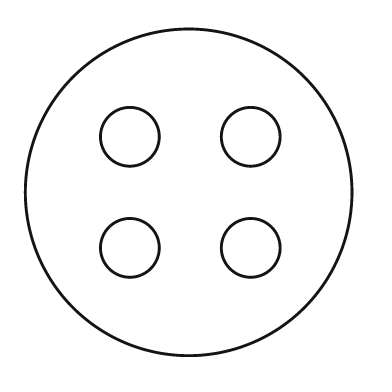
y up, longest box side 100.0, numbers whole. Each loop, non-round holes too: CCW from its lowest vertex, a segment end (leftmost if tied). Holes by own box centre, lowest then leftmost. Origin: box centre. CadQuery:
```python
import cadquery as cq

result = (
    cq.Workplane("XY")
    .moveTo(0.0, 0.0)
    .circle(50.0)
    .moveTo(-18.0, -17.0)
    .circle(9.0)
    .moveTo(19.0, -17.0)
    .circle(9.0)
    .moveTo(-18.0, 17.0)
    .circle(9.0)
    .moveTo(19.0, 17.0)
    .circle(9.0)
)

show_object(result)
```